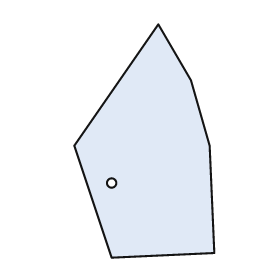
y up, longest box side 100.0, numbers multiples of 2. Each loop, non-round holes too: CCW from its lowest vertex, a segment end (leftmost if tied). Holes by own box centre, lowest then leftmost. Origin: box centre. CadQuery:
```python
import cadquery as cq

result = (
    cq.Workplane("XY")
    .moveTo(-14.0, -50.0)
    .lineTo(30.0, -48.0)
    .lineTo(28.0, -2.0)
    .lineTo(20.0, 26.0)
    .lineTo(6.0, 50.0)
    .lineTo(-30.0, -2.0)
    .close()
    .moveTo(-14.0, -18.0)
    .circle(2.0)
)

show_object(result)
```